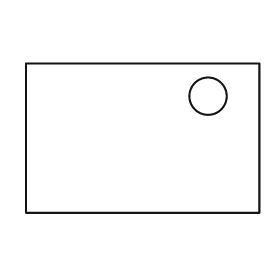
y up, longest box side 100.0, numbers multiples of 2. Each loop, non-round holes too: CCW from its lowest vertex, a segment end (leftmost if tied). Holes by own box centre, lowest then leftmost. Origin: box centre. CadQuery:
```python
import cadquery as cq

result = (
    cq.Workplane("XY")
    .moveTo(-50.0, -32.0)
    .lineTo(50.0, -32.0)
    .lineTo(50.0, 32.0)
    .lineTo(-50.0, 32.0)
    .close()
    .moveTo(28.0, 18.0)
    .circle(8.0)
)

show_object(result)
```